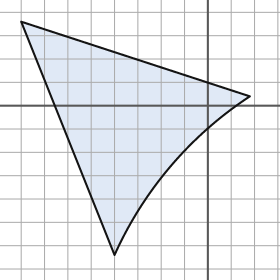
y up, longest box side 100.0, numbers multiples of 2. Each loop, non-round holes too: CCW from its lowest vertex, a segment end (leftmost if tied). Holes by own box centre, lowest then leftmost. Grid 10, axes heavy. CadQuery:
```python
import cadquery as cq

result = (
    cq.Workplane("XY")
    .moveTo(-40.0, -64.0)
    .threePointArc((-16.0, -26.0), (18.0, 4.0))
    .lineTo(-80.0, 36.0)
    .close()
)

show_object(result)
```